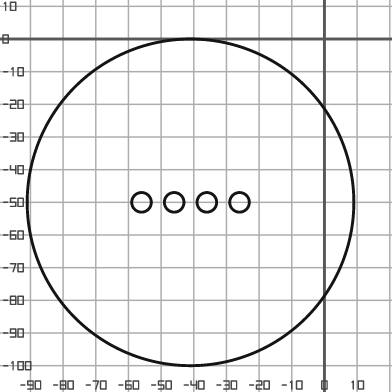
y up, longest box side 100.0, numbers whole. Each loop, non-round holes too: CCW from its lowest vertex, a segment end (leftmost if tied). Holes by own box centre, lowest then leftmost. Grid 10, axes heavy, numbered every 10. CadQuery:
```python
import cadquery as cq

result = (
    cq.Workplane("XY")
    .moveTo(-41.0, -50.0)
    .circle(50.0)
    .moveTo(-56.0, -50.0)
    .circle(3.0)
    .moveTo(-46.0, -50.0)
    .circle(3.0)
    .moveTo(-36.0, -50.0)
    .circle(3.0)
    .moveTo(-26.0, -50.0)
    .circle(3.0)
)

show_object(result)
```